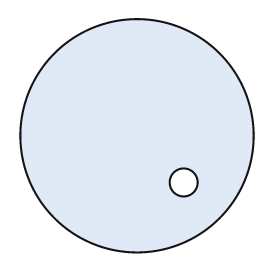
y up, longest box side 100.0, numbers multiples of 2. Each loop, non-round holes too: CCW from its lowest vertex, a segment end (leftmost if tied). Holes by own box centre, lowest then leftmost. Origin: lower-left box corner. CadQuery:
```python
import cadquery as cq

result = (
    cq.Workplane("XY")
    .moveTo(50.0, 50.0)
    .circle(50.0)
    .moveTo(70.0, 30.0)
    .circle(6.0)
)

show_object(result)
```